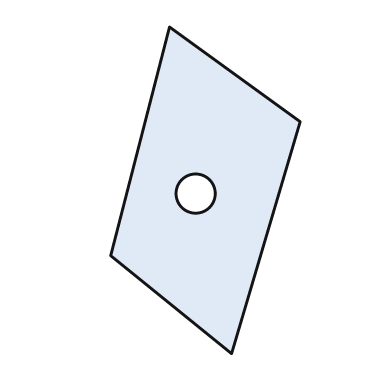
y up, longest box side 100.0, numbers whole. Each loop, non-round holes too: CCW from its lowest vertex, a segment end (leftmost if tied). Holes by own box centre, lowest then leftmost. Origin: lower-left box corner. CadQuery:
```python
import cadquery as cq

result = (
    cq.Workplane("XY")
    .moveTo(37.0, 0.0)
    .lineTo(58.0, 71.0)
    .lineTo(18.0, 100.0)
    .lineTo(0.0, 30.0)
    .close()
    .moveTo(26.0, 49.0)
    .circle(6.0)
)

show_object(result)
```